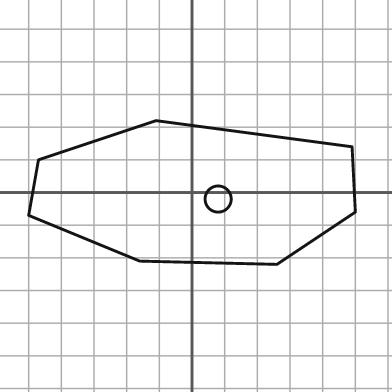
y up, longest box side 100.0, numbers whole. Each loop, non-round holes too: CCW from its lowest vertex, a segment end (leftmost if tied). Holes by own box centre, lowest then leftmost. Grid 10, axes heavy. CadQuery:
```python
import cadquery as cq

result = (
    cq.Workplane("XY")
    .moveTo(26.0, -22.0)
    .lineTo(50.0, -6.0)
    .lineTo(49.0, 14.0)
    .lineTo(-11.0, 22.0)
    .lineTo(-47.0, 10.0)
    .lineTo(-50.0, -7.0)
    .lineTo(-16.0, -21.0)
    .close()
    .moveTo(8.0, -2.0)
    .circle(4.0)
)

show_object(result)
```